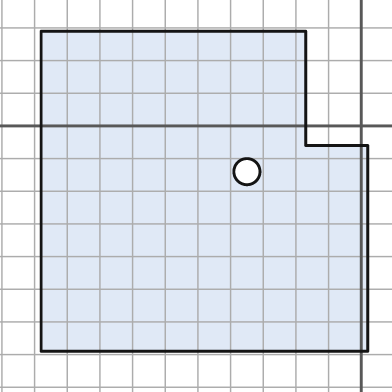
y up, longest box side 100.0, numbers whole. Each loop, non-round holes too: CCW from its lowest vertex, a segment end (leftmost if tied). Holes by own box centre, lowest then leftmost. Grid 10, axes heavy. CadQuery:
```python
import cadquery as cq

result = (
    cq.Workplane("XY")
    .moveTo(-98.0, -69.0)
    .lineTo(2.0, -69.0)
    .lineTo(2.0, -6.0)
    .lineTo(-17.0, -6.0)
    .lineTo(-17.0, 29.0)
    .lineTo(-98.0, 29.0)
    .close()
    .moveTo(-35.0, -14.0)
    .circle(4.0)
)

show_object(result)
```